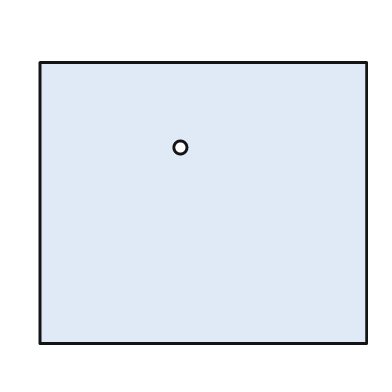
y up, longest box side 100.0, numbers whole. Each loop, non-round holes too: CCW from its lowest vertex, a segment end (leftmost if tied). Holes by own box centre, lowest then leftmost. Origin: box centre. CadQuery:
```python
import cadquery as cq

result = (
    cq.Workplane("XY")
    .moveTo(-50.0, -43.0)
    .lineTo(50.0, -43.0)
    .lineTo(50.0, 43.0)
    .lineTo(-50.0, 43.0)
    .close()
    .moveTo(-7.0, 17.0)
    .circle(2.0)
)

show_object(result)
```